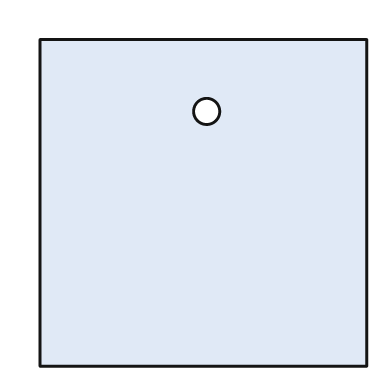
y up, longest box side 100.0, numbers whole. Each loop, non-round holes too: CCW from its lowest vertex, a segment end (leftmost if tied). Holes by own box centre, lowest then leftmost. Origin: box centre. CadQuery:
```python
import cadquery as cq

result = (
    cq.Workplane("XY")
    .moveTo(-50.0, -50.0)
    .lineTo(50.0, -50.0)
    .lineTo(50.0, 50.0)
    .lineTo(-50.0, 50.0)
    .close()
    .moveTo(1.0, 28.0)
    .circle(4.0)
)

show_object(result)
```